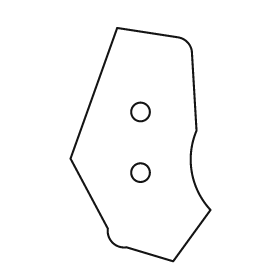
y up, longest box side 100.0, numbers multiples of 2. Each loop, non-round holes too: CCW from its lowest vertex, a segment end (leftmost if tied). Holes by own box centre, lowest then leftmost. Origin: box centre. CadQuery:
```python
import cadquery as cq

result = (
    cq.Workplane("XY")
    .moveTo(14.0, -50.0)
    .lineTo(30.0, -28.0)
    .threePointArc((22.0, -12.0), (24.0, 6.0))
    .lineTo(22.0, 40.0)
    .threePointArc((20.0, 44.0), (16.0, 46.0))
    .lineTo(-10.0, 50.0)
    .lineTo(-30.0, -6.0)
    .lineTo(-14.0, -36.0)
    .threePointArc((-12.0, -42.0), (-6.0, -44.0))
    .close()
    .moveTo(0.0, -12.0)
    .circle(4.0)
    .moveTo(0.0, 14.0)
    .circle(4.0)
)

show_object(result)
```